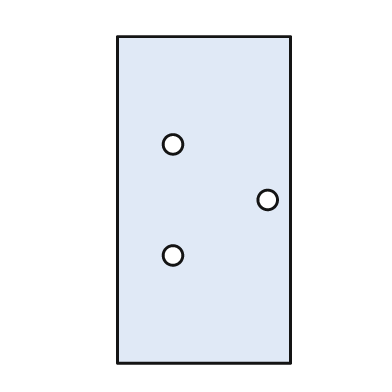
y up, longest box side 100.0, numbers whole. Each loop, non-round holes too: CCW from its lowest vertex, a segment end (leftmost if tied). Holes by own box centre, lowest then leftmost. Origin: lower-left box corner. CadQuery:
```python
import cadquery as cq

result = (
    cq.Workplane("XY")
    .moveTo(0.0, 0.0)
    .lineTo(53.0, 0.0)
    .lineTo(53.0, 100.0)
    .lineTo(0.0, 100.0)
    .close()
    .moveTo(17.0, 33.0)
    .circle(3.0)
    .moveTo(46.0, 50.0)
    .circle(3.0)
    .moveTo(17.0, 67.0)
    .circle(3.0)
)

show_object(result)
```